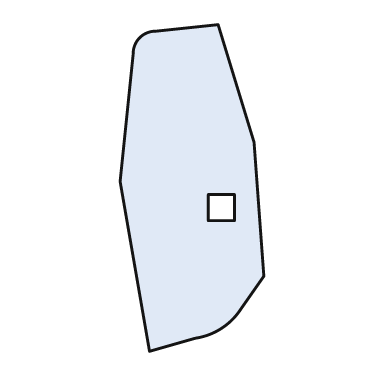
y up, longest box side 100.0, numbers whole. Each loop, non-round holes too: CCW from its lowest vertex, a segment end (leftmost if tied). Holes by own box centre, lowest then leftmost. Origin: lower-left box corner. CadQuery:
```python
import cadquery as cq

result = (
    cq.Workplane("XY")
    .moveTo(9.0, 0.0)
    .lineTo(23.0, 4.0)
    .threePointArc((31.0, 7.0), (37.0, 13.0))
    .lineTo(44.0, 23.0)
    .lineTo(41.0, 64.0)
    .lineTo(30.0, 100.0)
    .lineTo(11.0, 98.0)
    .threePointArc((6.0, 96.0), (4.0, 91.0))
    .lineTo(0.0, 52.0)
    .close()
    .moveTo(27.0, 40.0)
    .lineTo(35.0, 40.0)
    .lineTo(35.0, 48.0)
    .lineTo(27.0, 48.0)
    .close()
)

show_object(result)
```